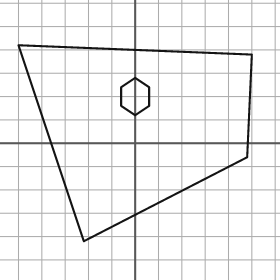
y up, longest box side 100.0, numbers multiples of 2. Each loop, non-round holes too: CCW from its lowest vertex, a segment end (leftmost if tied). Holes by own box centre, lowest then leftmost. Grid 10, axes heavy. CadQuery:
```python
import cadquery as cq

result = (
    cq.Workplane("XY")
    .moveTo(-22.0, -42.0)
    .lineTo(48.0, -6.0)
    .lineTo(50.0, 38.0)
    .lineTo(-50.0, 42.0)
    .close()
    .moveTo(0.0, 12.0)
    .lineTo(6.0, 16.0)
    .lineTo(6.0, 24.0)
    .lineTo(0.0, 28.0)
    .lineTo(-6.0, 24.0)
    .lineTo(-6.0, 16.0)
    .close()
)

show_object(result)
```